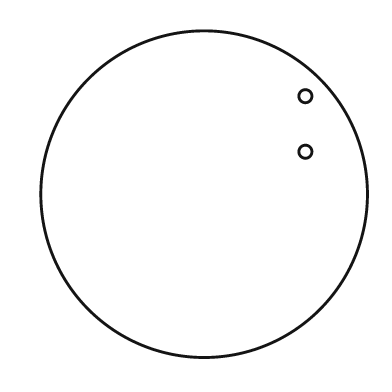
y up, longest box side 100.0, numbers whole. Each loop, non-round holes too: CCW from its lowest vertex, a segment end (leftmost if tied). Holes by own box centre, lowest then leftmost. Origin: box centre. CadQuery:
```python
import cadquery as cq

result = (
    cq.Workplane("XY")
    .moveTo(0.0, 0.0)
    .circle(50.0)
    .moveTo(31.0, 13.0)
    .circle(2.0)
    .moveTo(31.0, 30.0)
    .circle(2.0)
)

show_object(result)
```